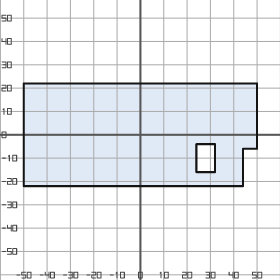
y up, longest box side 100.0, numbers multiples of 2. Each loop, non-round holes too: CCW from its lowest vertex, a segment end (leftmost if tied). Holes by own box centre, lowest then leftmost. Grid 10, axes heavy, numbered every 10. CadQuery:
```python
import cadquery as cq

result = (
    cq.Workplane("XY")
    .moveTo(-50.0, -22.0)
    .lineTo(44.0, -22.0)
    .lineTo(44.0, -6.0)
    .lineTo(50.0, -6.0)
    .lineTo(50.0, 22.0)
    .lineTo(-50.0, 22.0)
    .close()
    .moveTo(24.0, -16.0)
    .lineTo(32.0, -16.0)
    .lineTo(32.0, -4.0)
    .lineTo(24.0, -4.0)
    .close()
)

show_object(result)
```